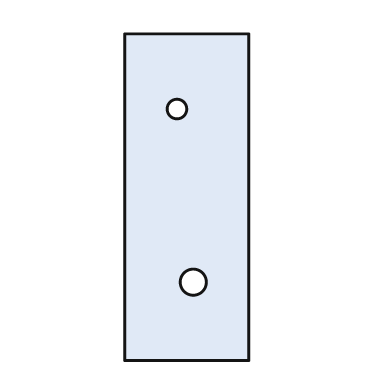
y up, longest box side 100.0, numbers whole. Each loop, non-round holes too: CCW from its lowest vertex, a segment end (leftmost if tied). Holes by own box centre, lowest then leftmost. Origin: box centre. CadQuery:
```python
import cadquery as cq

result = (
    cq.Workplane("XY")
    .moveTo(-19.0, -50.0)
    .lineTo(19.0, -50.0)
    .lineTo(19.0, 50.0)
    .lineTo(-19.0, 50.0)
    .close()
    .moveTo(2.0, -26.0)
    .circle(4.0)
    .moveTo(-3.0, 27.0)
    .circle(3.0)
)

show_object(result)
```